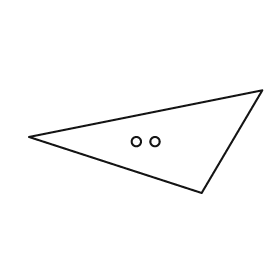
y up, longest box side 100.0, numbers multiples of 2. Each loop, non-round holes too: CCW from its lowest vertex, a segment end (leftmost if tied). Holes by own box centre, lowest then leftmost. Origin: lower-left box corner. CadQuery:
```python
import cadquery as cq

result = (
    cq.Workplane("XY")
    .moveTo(74.0, 0.0)
    .lineTo(100.0, 44.0)
    .lineTo(0.0, 24.0)
    .close()
    .moveTo(46.0, 22.0)
    .circle(2.0)
    .moveTo(54.0, 22.0)
    .circle(2.0)
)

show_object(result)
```